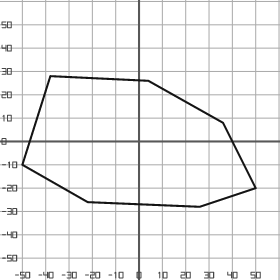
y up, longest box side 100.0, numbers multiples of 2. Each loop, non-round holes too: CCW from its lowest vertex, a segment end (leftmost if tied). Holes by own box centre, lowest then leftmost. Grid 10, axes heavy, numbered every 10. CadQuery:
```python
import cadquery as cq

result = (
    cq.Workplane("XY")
    .moveTo(26.0, -28.0)
    .lineTo(50.0, -20.0)
    .lineTo(36.0, 8.0)
    .lineTo(4.0, 26.0)
    .lineTo(-38.0, 28.0)
    .lineTo(-50.0, -10.0)
    .lineTo(-22.0, -26.0)
    .close()
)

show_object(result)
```